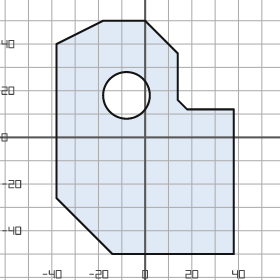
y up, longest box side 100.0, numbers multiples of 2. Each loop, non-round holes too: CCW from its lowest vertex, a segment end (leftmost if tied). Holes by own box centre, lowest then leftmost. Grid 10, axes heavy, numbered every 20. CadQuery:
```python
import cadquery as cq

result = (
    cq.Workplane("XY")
    .moveTo(-14.0, -50.0)
    .lineTo(38.0, -50.0)
    .lineTo(38.0, 12.0)
    .lineTo(18.0, 12.0)
    .lineTo(14.0, 16.0)
    .lineTo(14.0, 36.0)
    .lineTo(0.0, 50.0)
    .lineTo(-18.0, 50.0)
    .lineTo(-38.0, 40.0)
    .lineTo(-38.0, -26.0)
    .close()
    .moveTo(-8.0, 18.0)
    .circle(10.0)
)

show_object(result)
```